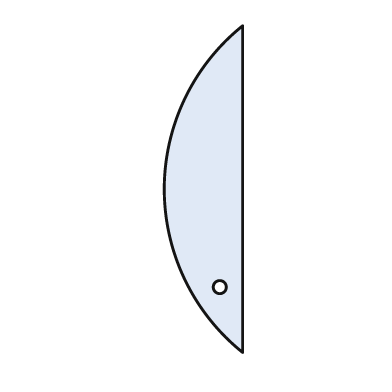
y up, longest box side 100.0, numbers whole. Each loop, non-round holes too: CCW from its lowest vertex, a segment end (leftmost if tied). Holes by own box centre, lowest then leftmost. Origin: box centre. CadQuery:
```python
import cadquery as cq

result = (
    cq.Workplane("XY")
    .moveTo(12.0, -50.0)
    .lineTo(12.0, 50.0)
    .threePointArc((-12.0, 0.0), (12.0, -50.0))
    .close()
    .moveTo(5.0, -30.0)
    .circle(2.0)
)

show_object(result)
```